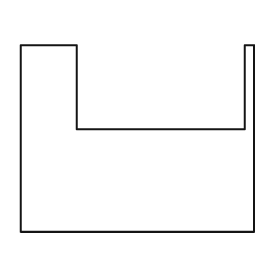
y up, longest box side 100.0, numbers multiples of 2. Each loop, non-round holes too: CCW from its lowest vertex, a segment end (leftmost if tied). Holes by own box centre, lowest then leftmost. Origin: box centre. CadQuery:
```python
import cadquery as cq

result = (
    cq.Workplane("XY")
    .moveTo(-50.0, -40.0)
    .lineTo(50.0, -40.0)
    .lineTo(50.0, 40.0)
    .lineTo(46.0, 40.0)
    .lineTo(46.0, 4.0)
    .lineTo(-26.0, 4.0)
    .lineTo(-26.0, 40.0)
    .lineTo(-50.0, 40.0)
    .close()
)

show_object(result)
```